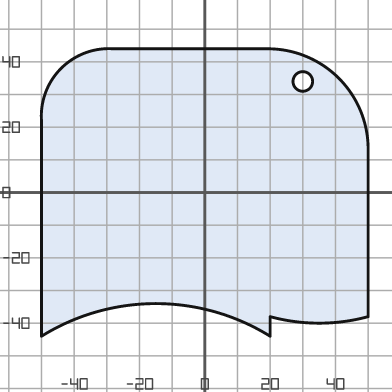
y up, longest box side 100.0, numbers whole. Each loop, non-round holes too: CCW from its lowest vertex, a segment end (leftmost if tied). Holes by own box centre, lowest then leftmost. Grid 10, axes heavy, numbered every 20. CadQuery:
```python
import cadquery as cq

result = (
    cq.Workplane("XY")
    .moveTo(-50.0, -44.0)
    .threePointArc((-15.0, -34.0), (20.0, -44.0))
    .lineTo(20.0, -38.0)
    .threePointArc((35.0, -40.0), (50.0, -38.0))
    .lineTo(50.0, 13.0)
    .threePointArc((41.0, 35.0), (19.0, 44.0))
    .lineTo(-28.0, 44.0)
    .threePointArc((-44.0, 38.0), (-50.0, 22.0))
    .close()
    .moveTo(30.0, 34.0)
    .circle(3.0)
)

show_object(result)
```